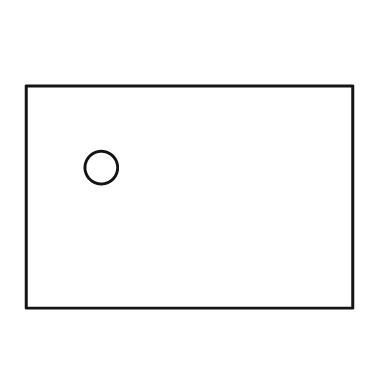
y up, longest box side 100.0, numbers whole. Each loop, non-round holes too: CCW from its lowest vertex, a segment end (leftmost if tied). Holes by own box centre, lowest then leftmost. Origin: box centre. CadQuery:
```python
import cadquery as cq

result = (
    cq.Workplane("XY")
    .moveTo(-50.0, -34.0)
    .lineTo(50.0, -34.0)
    .lineTo(50.0, 34.0)
    .lineTo(-50.0, 34.0)
    .close()
    .moveTo(-27.0, 9.0)
    .circle(5.0)
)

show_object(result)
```